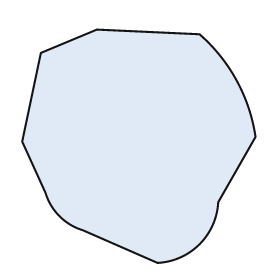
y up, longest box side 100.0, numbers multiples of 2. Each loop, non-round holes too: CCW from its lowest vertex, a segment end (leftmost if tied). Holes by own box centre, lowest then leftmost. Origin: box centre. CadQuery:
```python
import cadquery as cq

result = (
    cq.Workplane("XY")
    .moveTo(8.0, -50.0)
    .threePointArc((26.0, -42.0), (34.0, -24.0))
    .lineTo(50.0, 4.0)
    .threePointArc((42.0, 28.0), (26.0, 48.0))
    .lineTo(-18.0, 50.0)
    .lineTo(-42.0, 40.0)
    .lineTo(-50.0, 2.0)
    .lineTo(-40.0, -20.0)
    .threePointArc((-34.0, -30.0), (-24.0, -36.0))
    .close()
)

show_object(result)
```